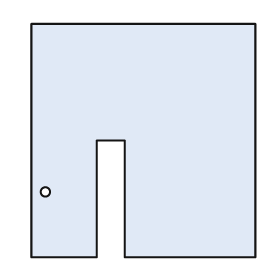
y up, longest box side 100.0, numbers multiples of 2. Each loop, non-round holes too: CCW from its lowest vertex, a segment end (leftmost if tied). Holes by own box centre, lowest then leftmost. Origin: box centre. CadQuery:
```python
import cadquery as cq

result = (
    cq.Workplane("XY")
    .moveTo(-48.0, -50.0)
    .lineTo(-20.0, -50.0)
    .lineTo(-20.0, 0.0)
    .lineTo(-8.0, 0.0)
    .lineTo(-8.0, -50.0)
    .lineTo(48.0, -50.0)
    .lineTo(48.0, 50.0)
    .lineTo(-48.0, 50.0)
    .close()
    .moveTo(-42.0, -22.0)
    .circle(2.0)
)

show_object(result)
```